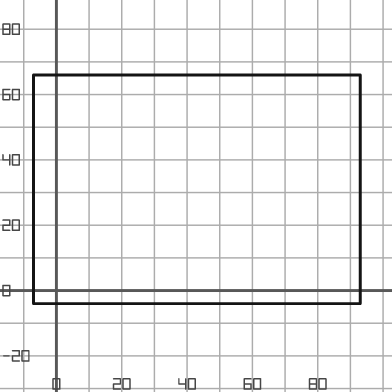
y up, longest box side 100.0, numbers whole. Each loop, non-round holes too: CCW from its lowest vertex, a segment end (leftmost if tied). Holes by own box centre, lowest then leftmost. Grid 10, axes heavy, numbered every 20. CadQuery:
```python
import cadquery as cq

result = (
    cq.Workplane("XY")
    .moveTo(-7.0, -4.0)
    .lineTo(93.0, -4.0)
    .lineTo(93.0, 66.0)
    .lineTo(-7.0, 66.0)
    .close()
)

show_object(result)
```